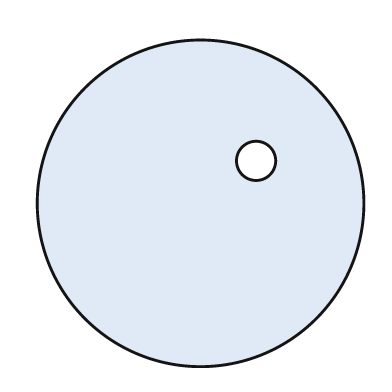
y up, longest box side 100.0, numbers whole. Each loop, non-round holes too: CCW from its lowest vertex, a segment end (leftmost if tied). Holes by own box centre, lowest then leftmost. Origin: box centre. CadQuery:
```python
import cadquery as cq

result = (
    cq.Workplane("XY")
    .moveTo(0.0, 0.0)
    .circle(50.0)
    .moveTo(17.0, 13.0)
    .circle(6.0)
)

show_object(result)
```